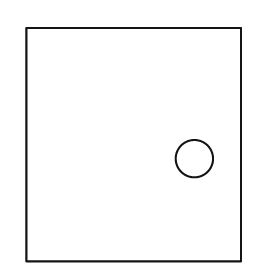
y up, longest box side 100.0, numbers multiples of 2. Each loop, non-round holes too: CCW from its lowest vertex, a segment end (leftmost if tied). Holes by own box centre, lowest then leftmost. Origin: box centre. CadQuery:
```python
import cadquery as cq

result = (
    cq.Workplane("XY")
    .moveTo(-46.0, -50.0)
    .lineTo(46.0, -50.0)
    .lineTo(46.0, 50.0)
    .lineTo(-46.0, 50.0)
    .close()
    .moveTo(26.0, -6.0)
    .circle(8.0)
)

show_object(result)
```